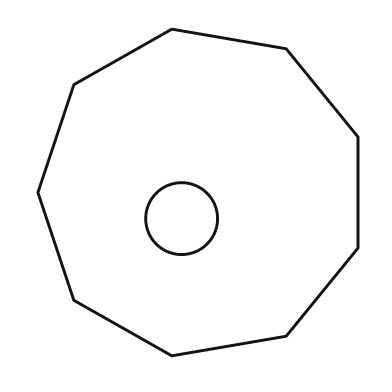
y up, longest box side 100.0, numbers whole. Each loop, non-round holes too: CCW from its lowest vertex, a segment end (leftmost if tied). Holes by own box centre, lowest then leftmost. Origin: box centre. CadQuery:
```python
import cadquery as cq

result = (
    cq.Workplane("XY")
    .moveTo(-8.0, -50.0)
    .lineTo(27.0, -44.0)
    .lineTo(49.0, -17.0)
    .lineTo(49.0, 17.0)
    .lineTo(27.0, 44.0)
    .lineTo(-8.0, 50.0)
    .lineTo(-38.0, 33.0)
    .lineTo(-49.0, 0.0)
    .lineTo(-38.0, -33.0)
    .close()
    .moveTo(-5.0, -8.0)
    .circle(11.0)
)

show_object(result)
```